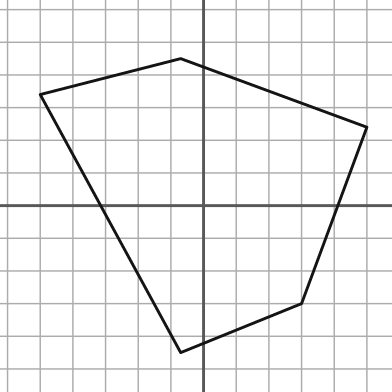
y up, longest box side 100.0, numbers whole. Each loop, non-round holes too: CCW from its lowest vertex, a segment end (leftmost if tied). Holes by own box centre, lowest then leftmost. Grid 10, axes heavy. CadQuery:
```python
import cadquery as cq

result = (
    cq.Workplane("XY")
    .moveTo(-7.0, -45.0)
    .lineTo(30.0, -30.0)
    .lineTo(50.0, 24.0)
    .lineTo(-7.0, 45.0)
    .lineTo(-50.0, 34.0)
    .close()
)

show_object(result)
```